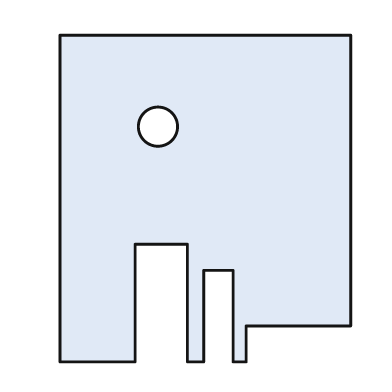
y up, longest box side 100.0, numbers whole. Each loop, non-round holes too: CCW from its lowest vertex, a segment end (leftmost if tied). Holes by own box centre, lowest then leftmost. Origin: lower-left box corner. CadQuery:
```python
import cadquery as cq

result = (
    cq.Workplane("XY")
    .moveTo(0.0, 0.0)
    .lineTo(23.0, 0.0)
    .lineTo(23.0, 36.0)
    .lineTo(39.0, 36.0)
    .lineTo(39.0, 0.0)
    .lineTo(44.0, 0.0)
    .lineTo(44.0, 28.0)
    .lineTo(53.0, 28.0)
    .lineTo(53.0, 0.0)
    .lineTo(57.0, 0.0)
    .lineTo(57.0, 11.0)
    .lineTo(89.0, 11.0)
    .lineTo(89.0, 100.0)
    .lineTo(0.0, 100.0)
    .close()
    .moveTo(30.0, 72.0)
    .circle(6.0)
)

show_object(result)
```